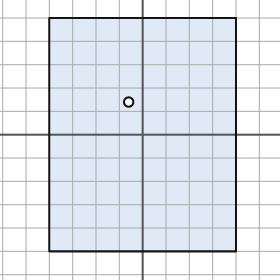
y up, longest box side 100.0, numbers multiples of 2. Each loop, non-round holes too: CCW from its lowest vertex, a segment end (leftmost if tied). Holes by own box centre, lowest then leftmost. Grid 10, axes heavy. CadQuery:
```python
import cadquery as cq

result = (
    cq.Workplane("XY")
    .moveTo(-40.0, -50.0)
    .lineTo(40.0, -50.0)
    .lineTo(40.0, 50.0)
    .lineTo(-40.0, 50.0)
    .close()
    .moveTo(-6.0, 14.0)
    .circle(2.0)
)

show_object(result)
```